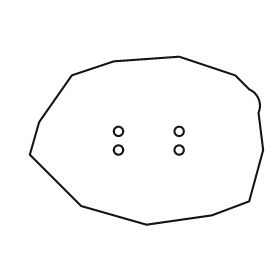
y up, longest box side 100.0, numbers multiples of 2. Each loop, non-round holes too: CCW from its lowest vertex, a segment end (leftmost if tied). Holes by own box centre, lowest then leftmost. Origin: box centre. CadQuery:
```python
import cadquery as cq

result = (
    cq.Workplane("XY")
    .moveTo(0.0, -36.0)
    .lineTo(28.0, -32.0)
    .lineTo(44.0, -26.0)
    .lineTo(50.0, -4.0)
    .lineTo(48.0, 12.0)
    .threePointArc((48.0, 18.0), (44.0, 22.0))
    .lineTo(38.0, 28.0)
    .lineTo(14.0, 36.0)
    .lineTo(-14.0, 34.0)
    .lineTo(-32.0, 28.0)
    .lineTo(-46.0, 8.0)
    .lineTo(-50.0, -6.0)
    .lineTo(-28.0, -28.0)
    .close()
    .moveTo(-12.0, -4.0)
    .circle(2.0)
    .moveTo(14.0, -4.0)
    .circle(2.0)
    .moveTo(-12.0, 4.0)
    .circle(2.0)
    .moveTo(14.0, 4.0)
    .circle(2.0)
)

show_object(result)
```